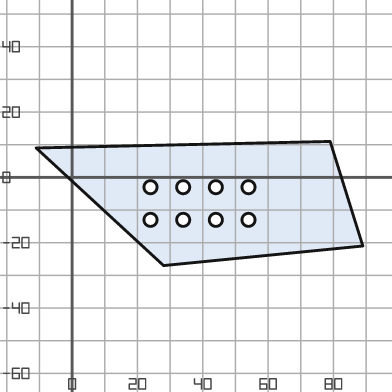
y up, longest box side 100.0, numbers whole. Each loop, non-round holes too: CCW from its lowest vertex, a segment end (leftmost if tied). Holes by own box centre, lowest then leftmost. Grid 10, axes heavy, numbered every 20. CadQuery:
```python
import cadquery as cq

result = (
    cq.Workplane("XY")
    .moveTo(28.0, -27.0)
    .lineTo(89.0, -21.0)
    .lineTo(79.0, 11.0)
    .lineTo(-11.0, 9.0)
    .close()
    .moveTo(24.0, -13.0)
    .circle(2.0)
    .moveTo(34.0, -13.0)
    .circle(2.0)
    .moveTo(44.0, -13.0)
    .circle(2.0)
    .moveTo(54.0, -13.0)
    .circle(2.0)
    .moveTo(24.0, -3.0)
    .circle(2.0)
    .moveTo(34.0, -3.0)
    .circle(2.0)
    .moveTo(44.0, -3.0)
    .circle(2.0)
    .moveTo(54.0, -3.0)
    .circle(2.0)
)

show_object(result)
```